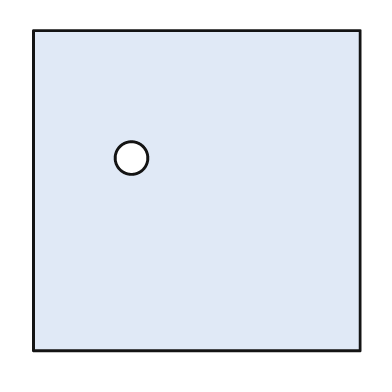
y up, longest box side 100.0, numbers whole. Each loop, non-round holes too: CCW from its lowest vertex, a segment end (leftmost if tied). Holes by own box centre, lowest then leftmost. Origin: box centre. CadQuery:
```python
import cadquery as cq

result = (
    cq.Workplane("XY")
    .moveTo(-50.0, -49.0)
    .lineTo(50.0, -49.0)
    .lineTo(50.0, 49.0)
    .lineTo(-50.0, 49.0)
    .close()
    .moveTo(-20.0, 10.0)
    .circle(5.0)
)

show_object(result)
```